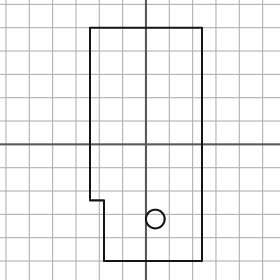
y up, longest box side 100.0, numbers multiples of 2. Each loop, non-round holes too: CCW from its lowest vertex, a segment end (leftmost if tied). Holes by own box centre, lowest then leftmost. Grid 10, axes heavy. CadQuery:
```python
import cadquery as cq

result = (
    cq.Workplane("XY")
    .moveTo(-18.0, -50.0)
    .lineTo(24.0, -50.0)
    .lineTo(24.0, 50.0)
    .lineTo(-24.0, 50.0)
    .lineTo(-24.0, -24.0)
    .lineTo(-18.0, -24.0)
    .close()
    .moveTo(4.0, -32.0)
    .circle(4.0)
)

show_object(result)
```